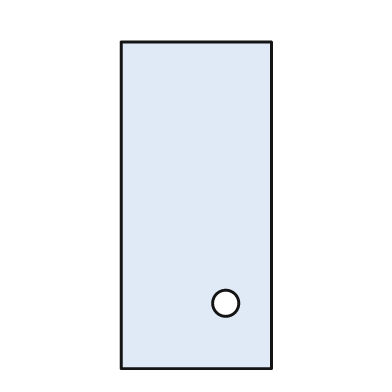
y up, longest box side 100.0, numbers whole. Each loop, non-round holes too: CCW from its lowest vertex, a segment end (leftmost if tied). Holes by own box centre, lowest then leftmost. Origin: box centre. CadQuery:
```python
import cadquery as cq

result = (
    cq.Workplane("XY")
    .moveTo(-23.0, -50.0)
    .lineTo(23.0, -50.0)
    .lineTo(23.0, 50.0)
    .lineTo(-23.0, 50.0)
    .close()
    .moveTo(9.0, -30.0)
    .circle(4.0)
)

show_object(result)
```